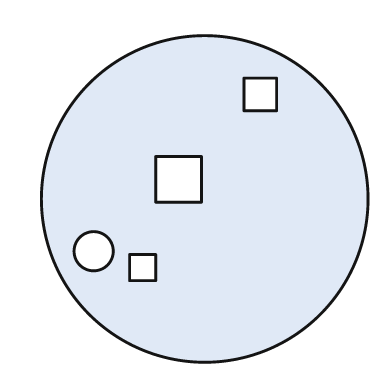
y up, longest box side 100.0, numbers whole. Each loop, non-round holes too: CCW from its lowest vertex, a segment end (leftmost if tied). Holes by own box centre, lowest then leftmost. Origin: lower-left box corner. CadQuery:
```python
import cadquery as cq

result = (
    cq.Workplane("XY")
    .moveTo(50.0, 50.0)
    .circle(50.0)
    .moveTo(27.0, 25.0)
    .lineTo(35.0, 25.0)
    .lineTo(35.0, 33.0)
    .lineTo(27.0, 33.0)
    .close()
    .moveTo(16.0, 34.0)
    .circle(6.0)
    .moveTo(35.0, 49.0)
    .lineTo(49.0, 49.0)
    .lineTo(49.0, 63.0)
    .lineTo(35.0, 63.0)
    .close()
    .moveTo(62.0, 77.0)
    .lineTo(72.0, 77.0)
    .lineTo(72.0, 87.0)
    .lineTo(62.0, 87.0)
    .close()
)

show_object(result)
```